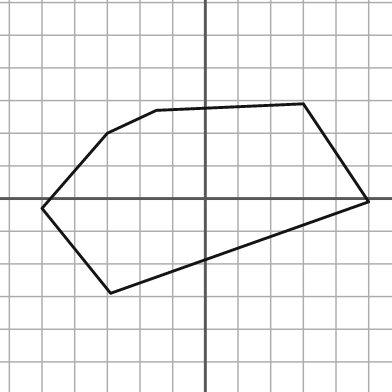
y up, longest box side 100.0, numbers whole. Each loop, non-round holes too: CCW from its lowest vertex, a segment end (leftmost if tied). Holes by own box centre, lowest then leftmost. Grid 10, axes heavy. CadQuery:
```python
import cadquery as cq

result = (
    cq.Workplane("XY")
    .moveTo(-29.0, -29.0)
    .lineTo(50.0, -1.0)
    .lineTo(30.0, 29.0)
    .lineTo(-15.0, 27.0)
    .lineTo(-30.0, 20.0)
    .lineTo(-50.0, -3.0)
    .close()
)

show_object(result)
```